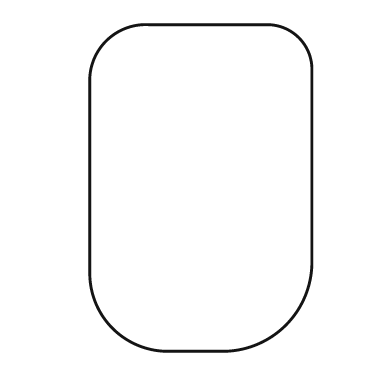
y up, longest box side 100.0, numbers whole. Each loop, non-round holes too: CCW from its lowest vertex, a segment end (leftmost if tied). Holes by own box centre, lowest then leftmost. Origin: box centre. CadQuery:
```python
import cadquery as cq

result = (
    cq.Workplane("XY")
    .moveTo(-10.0, -50.0)
    .lineTo(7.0, -50.0)
    .threePointArc((26.0, -42.0), (34.0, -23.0))
    .lineTo(34.0, 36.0)
    .threePointArc((30.0, 46.0), (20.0, 50.0))
    .lineTo(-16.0, 50.0)
    .threePointArc((-29.0, 45.0), (-34.0, 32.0))
    .lineTo(-34.0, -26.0)
    .threePointArc((-27.0, -43.0), (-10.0, -50.0))
    .close()
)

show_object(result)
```